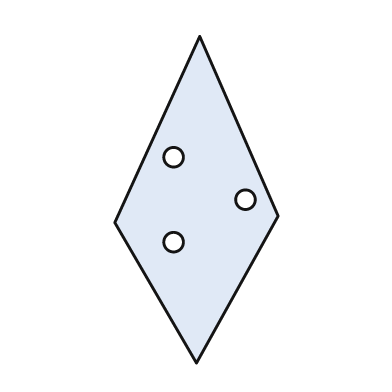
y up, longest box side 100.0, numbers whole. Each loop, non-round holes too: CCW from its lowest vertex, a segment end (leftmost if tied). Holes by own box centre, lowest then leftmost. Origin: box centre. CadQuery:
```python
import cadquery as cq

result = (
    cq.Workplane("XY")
    .moveTo(0.0, -50.0)
    .lineTo(25.0, -5.0)
    .lineTo(1.0, 50.0)
    .lineTo(-25.0, -7.0)
    .close()
    .moveTo(-7.0, -13.0)
    .circle(3.0)
    .moveTo(15.0, 0.0)
    .circle(3.0)
    .moveTo(-7.0, 13.0)
    .circle(3.0)
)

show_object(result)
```